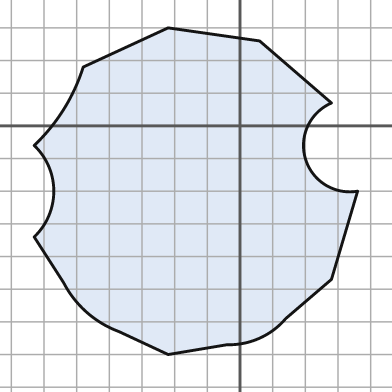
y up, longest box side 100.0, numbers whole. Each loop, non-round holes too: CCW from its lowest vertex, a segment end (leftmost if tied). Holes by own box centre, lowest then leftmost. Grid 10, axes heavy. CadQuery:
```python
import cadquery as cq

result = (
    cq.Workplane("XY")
    .moveTo(-22.0, -70.0)
    .lineTo(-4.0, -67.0)
    .threePointArc((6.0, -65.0), (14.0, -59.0))
    .lineTo(28.0, -47.0)
    .lineTo(36.0, -20.0)
    .threePointArc((20.0, -10.0), (28.0, 7.0))
    .lineTo(6.0, 26.0)
    .lineTo(-22.0, 30.0)
    .lineTo(-48.0, 18.0)
    .threePointArc((-54.0, 5.0), (-63.0, -6.0))
    .threePointArc((-57.0, -20.0), (-63.0, -34.0))
    .lineTo(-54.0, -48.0)
    .threePointArc((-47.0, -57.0), (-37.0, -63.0))
    .close()
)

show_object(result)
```